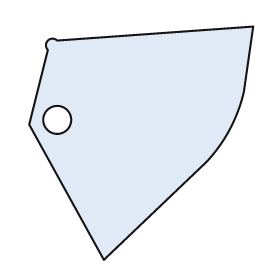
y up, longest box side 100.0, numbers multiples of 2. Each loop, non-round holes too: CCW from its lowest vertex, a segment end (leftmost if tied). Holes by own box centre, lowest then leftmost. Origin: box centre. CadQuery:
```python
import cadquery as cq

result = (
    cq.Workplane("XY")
    .moveTo(-16.0, -50.0)
    .lineTo(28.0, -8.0)
    .threePointArc((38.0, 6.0), (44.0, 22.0))
    .lineTo(48.0, 50.0)
    .lineTo(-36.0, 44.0)
    .threePointArc((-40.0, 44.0), (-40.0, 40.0))
    .lineTo(-48.0, 8.0)
    .close()
    .moveTo(-36.0, 10.0)
    .circle(6.0)
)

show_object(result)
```